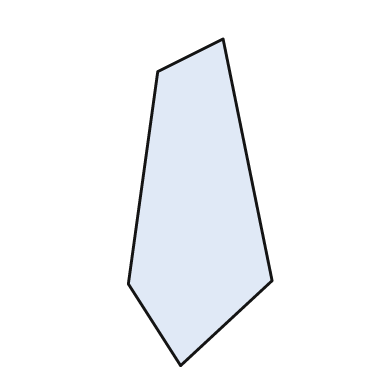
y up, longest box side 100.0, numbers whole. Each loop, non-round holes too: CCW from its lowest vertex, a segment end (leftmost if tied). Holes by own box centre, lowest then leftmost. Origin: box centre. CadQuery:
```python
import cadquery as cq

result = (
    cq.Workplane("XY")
    .moveTo(-6.0, -50.0)
    .lineTo(22.0, -24.0)
    .lineTo(7.0, 50.0)
    .lineTo(-13.0, 40.0)
    .lineTo(-22.0, -25.0)
    .close()
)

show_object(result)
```